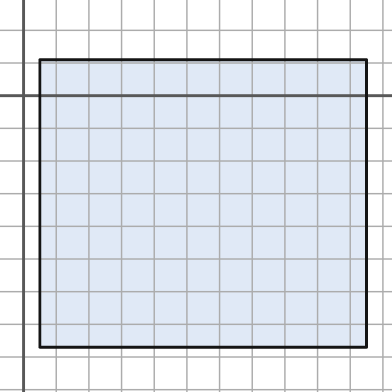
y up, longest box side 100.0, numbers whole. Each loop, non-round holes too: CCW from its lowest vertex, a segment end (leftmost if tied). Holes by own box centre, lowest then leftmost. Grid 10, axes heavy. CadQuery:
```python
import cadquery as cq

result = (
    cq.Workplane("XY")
    .moveTo(5.0, -77.0)
    .lineTo(105.0, -77.0)
    .lineTo(105.0, 11.0)
    .lineTo(5.0, 11.0)
    .close()
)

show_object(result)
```